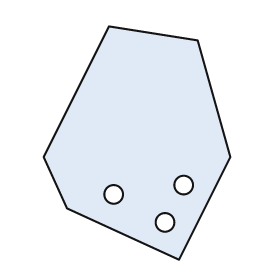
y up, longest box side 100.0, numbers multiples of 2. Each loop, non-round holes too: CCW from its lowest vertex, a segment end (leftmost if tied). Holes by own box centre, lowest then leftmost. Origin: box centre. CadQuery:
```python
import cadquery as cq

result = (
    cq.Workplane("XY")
    .moveTo(18.0, -50.0)
    .lineTo(40.0, -6.0)
    .lineTo(26.0, 44.0)
    .lineTo(-12.0, 50.0)
    .lineTo(-40.0, -6.0)
    .lineTo(-30.0, -28.0)
    .close()
    .moveTo(12.0, -34.0)
    .circle(4.0)
    .moveTo(-10.0, -22.0)
    .circle(4.0)
    .moveTo(20.0, -18.0)
    .circle(4.0)
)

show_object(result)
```